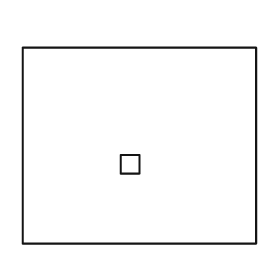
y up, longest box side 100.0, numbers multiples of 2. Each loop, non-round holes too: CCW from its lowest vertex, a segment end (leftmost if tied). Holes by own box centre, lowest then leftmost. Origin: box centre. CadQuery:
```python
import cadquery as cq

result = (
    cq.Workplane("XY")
    .moveTo(-50.0, -42.0)
    .lineTo(50.0, -42.0)
    .lineTo(50.0, 42.0)
    .lineTo(-50.0, 42.0)
    .close()
    .moveTo(-8.0, -12.0)
    .lineTo(0.0, -12.0)
    .lineTo(0.0, -4.0)
    .lineTo(-8.0, -4.0)
    .close()
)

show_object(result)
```